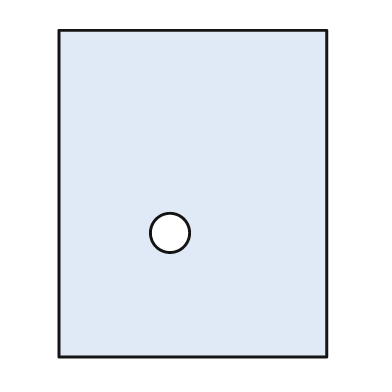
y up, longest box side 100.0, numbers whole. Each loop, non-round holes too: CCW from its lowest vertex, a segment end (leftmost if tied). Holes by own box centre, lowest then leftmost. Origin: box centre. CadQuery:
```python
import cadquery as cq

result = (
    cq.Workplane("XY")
    .moveTo(-41.0, -50.0)
    .lineTo(41.0, -50.0)
    .lineTo(41.0, 50.0)
    .lineTo(-41.0, 50.0)
    .close()
    .moveTo(-7.0, -12.0)
    .circle(6.0)
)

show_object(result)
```